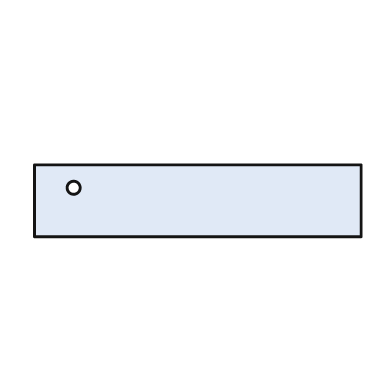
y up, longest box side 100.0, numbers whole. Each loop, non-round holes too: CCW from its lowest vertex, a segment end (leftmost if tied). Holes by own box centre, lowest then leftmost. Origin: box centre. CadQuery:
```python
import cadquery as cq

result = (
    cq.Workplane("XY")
    .moveTo(-50.0, -11.0)
    .lineTo(50.0, -11.0)
    .lineTo(50.0, 11.0)
    .lineTo(-50.0, 11.0)
    .close()
    .moveTo(-38.0, 4.0)
    .circle(2.0)
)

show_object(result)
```